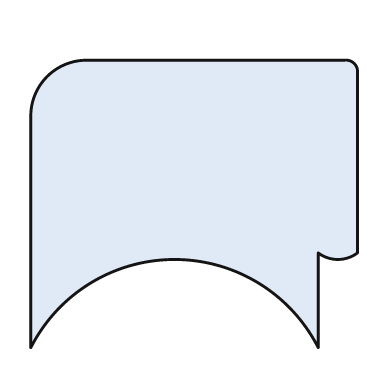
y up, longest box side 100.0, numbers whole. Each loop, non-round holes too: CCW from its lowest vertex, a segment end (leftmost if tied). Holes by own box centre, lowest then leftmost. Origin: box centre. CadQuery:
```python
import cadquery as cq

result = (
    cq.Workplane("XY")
    .moveTo(-50.0, -44.0)
    .threePointArc((-6.0, -17.0), (38.0, -44.0))
    .lineTo(38.0, -15.0)
    .threePointArc((44.0, -17.0), (50.0, -15.0))
    .lineTo(50.0, 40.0)
    .threePointArc((49.0, 43.0), (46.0, 44.0))
    .lineTo(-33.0, 44.0)
    .threePointArc((-45.0, 39.0), (-50.0, 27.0))
    .close()
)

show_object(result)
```